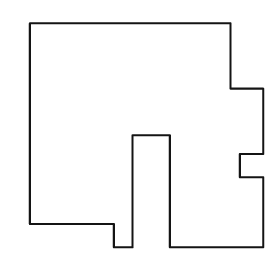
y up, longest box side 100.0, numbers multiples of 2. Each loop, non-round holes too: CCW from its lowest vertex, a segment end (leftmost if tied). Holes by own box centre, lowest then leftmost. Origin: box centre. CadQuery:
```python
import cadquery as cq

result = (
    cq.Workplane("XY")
    .moveTo(-14.0, -48.0)
    .lineTo(-6.0, -48.0)
    .lineTo(-6.0, 0.0)
    .lineTo(10.0, 0.0)
    .lineTo(10.0, -48.0)
    .lineTo(50.0, -48.0)
    .lineTo(50.0, -18.0)
    .lineTo(40.0, -18.0)
    .lineTo(40.0, -8.0)
    .lineTo(50.0, -8.0)
    .lineTo(50.0, 20.0)
    .lineTo(36.0, 20.0)
    .lineTo(36.0, 48.0)
    .lineTo(-50.0, 48.0)
    .lineTo(-50.0, -38.0)
    .lineTo(-14.0, -38.0)
    .close()
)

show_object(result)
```